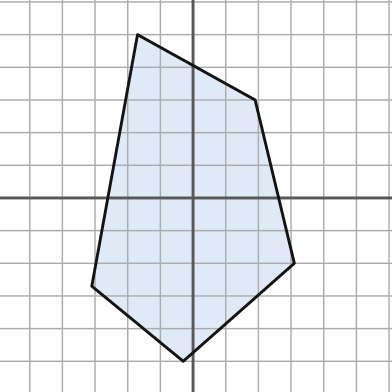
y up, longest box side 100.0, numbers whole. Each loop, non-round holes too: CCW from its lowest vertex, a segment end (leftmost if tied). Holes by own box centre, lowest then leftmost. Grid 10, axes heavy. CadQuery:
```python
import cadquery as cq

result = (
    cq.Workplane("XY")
    .moveTo(-3.0, -50.0)
    .lineTo(31.0, -20.0)
    .lineTo(19.0, 30.0)
    .lineTo(-17.0, 50.0)
    .lineTo(-31.0, -27.0)
    .close()
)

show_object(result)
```